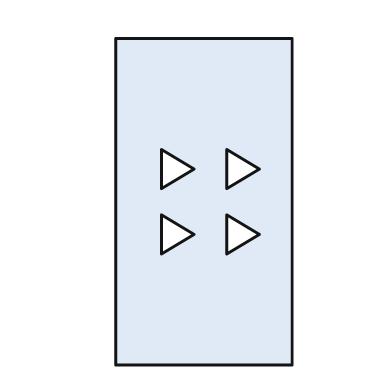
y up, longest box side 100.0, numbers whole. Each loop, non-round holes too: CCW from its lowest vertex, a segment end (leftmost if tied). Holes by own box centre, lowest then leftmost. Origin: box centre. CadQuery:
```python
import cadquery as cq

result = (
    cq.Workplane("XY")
    .moveTo(-27.0, -50.0)
    .lineTo(27.0, -50.0)
    .lineTo(27.0, 50.0)
    .lineTo(-27.0, 50.0)
    .close()
    .moveTo(-13.0, -16.0)
    .lineTo(-3.0, -10.0)
    .lineTo(-13.0, -4.0)
    .close()
    .moveTo(7.0, -16.0)
    .lineTo(17.0, -10.0)
    .lineTo(7.0, -4.0)
    .close()
    .moveTo(-13.0, 4.0)
    .lineTo(-3.0, 10.0)
    .lineTo(-13.0, 16.0)
    .close()
    .moveTo(7.0, 4.0)
    .lineTo(17.0, 10.0)
    .lineTo(7.0, 16.0)
    .close()
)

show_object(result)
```